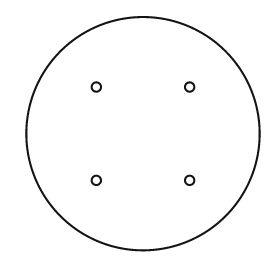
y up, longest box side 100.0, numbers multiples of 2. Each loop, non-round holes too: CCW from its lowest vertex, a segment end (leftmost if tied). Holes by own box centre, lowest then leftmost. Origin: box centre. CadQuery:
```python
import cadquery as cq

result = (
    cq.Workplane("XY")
    .moveTo(0.0, 0.0)
    .circle(50.0)
    .moveTo(-20.0, -20.0)
    .circle(2.0)
    .moveTo(20.0, -20.0)
    .circle(2.0)
    .moveTo(-20.0, 20.0)
    .circle(2.0)
    .moveTo(20.0, 20.0)
    .circle(2.0)
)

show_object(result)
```